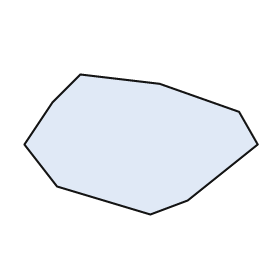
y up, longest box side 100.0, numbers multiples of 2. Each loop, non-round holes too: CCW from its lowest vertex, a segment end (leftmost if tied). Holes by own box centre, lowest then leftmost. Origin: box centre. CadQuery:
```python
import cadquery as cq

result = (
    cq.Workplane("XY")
    .moveTo(4.0, -30.0)
    .lineTo(20.0, -24.0)
    .lineTo(50.0, 0.0)
    .lineTo(42.0, 14.0)
    .lineTo(8.0, 26.0)
    .lineTo(-26.0, 30.0)
    .lineTo(-38.0, 18.0)
    .lineTo(-50.0, 0.0)
    .lineTo(-36.0, -18.0)
    .close()
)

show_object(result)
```